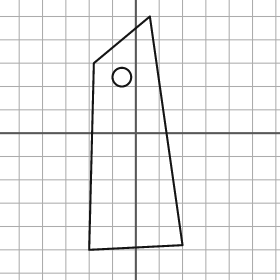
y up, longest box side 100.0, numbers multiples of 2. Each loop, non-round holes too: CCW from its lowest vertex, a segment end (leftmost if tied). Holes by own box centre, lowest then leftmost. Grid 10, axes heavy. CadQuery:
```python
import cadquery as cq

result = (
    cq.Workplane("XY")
    .moveTo(-20.0, -50.0)
    .lineTo(20.0, -48.0)
    .lineTo(6.0, 50.0)
    .lineTo(-18.0, 30.0)
    .close()
    .moveTo(-6.0, 24.0)
    .circle(4.0)
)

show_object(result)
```